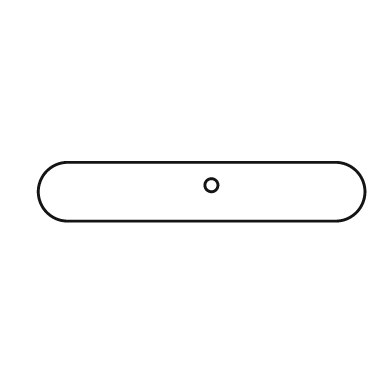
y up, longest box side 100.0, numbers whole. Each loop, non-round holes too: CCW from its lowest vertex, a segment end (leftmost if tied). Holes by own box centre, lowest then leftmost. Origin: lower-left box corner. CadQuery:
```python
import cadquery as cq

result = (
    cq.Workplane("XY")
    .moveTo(9.0, 0.0)
    .lineTo(91.0, 0.0)
    .threePointArc((100.0, 9.0), (91.0, 18.0))
    .lineTo(9.0, 18.0)
    .threePointArc((0.0, 9.0), (9.0, 0.0))
    .close()
    .moveTo(53.0, 11.0)
    .circle(2.0)
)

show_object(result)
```